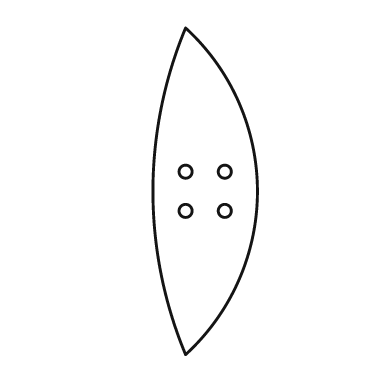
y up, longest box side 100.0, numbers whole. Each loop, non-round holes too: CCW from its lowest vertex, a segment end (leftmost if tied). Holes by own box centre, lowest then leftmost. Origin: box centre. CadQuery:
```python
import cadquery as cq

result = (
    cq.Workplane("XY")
    .moveTo(-6.0, -50.0)
    .threePointArc((16.0, 0.0), (-6.0, 50.0))
    .threePointArc((-16.0, 0.0), (-6.0, -50.0))
    .close()
    .moveTo(-6.0, -6.0)
    .circle(2.0)
    .moveTo(6.0, -6.0)
    .circle(2.0)
    .moveTo(-6.0, 6.0)
    .circle(2.0)
    .moveTo(6.0, 6.0)
    .circle(2.0)
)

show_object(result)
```